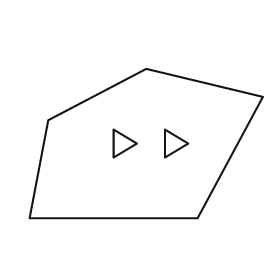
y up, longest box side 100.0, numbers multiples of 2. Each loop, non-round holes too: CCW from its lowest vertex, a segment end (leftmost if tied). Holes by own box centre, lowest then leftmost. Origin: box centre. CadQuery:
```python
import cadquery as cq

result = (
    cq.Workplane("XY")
    .moveTo(-50.0, -32.0)
    .lineTo(22.0, -32.0)
    .lineTo(50.0, 20.0)
    .lineTo(0.0, 32.0)
    .lineTo(-42.0, 10.0)
    .close()
    .moveTo(-14.0, -6.0)
    .lineTo(-4.0, 0.0)
    .lineTo(-14.0, 6.0)
    .close()
    .moveTo(8.0, -6.0)
    .lineTo(18.0, 0.0)
    .lineTo(8.0, 6.0)
    .close()
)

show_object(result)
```